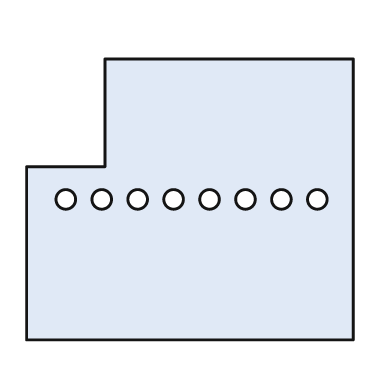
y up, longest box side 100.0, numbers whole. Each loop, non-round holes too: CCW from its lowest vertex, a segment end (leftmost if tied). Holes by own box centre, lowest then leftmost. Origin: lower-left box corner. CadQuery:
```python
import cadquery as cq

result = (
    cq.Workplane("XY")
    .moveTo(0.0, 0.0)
    .lineTo(100.0, 0.0)
    .lineTo(100.0, 86.0)
    .lineTo(24.0, 86.0)
    .lineTo(24.0, 53.0)
    .lineTo(0.0, 53.0)
    .close()
    .moveTo(12.0, 43.0)
    .circle(3.0)
    .moveTo(23.0, 43.0)
    .circle(3.0)
    .moveTo(34.0, 43.0)
    .circle(3.0)
    .moveTo(45.0, 43.0)
    .circle(3.0)
    .moveTo(56.0, 43.0)
    .circle(3.0)
    .moveTo(67.0, 43.0)
    .circle(3.0)
    .moveTo(78.0, 43.0)
    .circle(3.0)
    .moveTo(89.0, 43.0)
    .circle(3.0)
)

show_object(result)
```